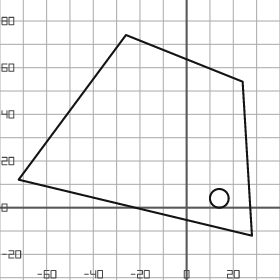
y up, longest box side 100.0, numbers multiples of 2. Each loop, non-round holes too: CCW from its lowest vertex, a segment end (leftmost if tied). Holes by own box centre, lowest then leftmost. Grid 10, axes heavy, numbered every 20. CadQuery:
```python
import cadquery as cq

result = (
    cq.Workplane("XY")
    .moveTo(28.0, -12.0)
    .lineTo(24.0, 54.0)
    .lineTo(-26.0, 74.0)
    .lineTo(-72.0, 12.0)
    .close()
    .moveTo(14.0, 4.0)
    .circle(4.0)
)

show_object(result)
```